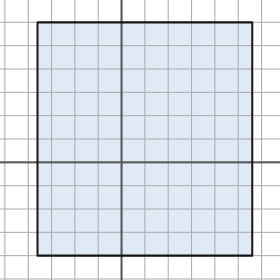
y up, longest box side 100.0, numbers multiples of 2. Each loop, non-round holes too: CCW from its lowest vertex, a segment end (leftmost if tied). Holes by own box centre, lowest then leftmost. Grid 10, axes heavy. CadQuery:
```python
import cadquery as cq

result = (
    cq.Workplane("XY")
    .moveTo(-36.0, -40.0)
    .lineTo(56.0, -40.0)
    .lineTo(56.0, 60.0)
    .lineTo(-36.0, 60.0)
    .close()
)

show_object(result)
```